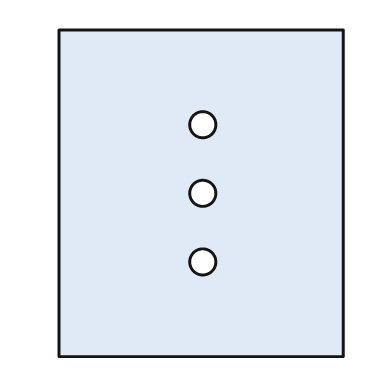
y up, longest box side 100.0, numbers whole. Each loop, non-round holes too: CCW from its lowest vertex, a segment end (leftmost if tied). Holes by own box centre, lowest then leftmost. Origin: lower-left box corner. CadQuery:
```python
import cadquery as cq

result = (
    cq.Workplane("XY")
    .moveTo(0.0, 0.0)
    .lineTo(87.0, 0.0)
    .lineTo(87.0, 100.0)
    .lineTo(0.0, 100.0)
    .close()
    .moveTo(44.0, 29.0)
    .circle(4.0)
    .moveTo(44.0, 50.0)
    .circle(4.0)
    .moveTo(44.0, 71.0)
    .circle(4.0)
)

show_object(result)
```